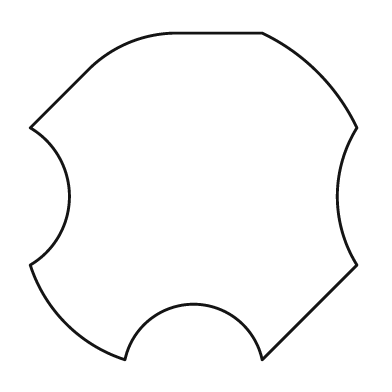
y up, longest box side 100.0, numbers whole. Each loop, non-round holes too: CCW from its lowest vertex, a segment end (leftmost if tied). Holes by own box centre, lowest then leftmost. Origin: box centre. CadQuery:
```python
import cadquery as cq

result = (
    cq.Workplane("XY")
    .moveTo(-21.0, -50.0)
    .threePointArc((0.0, -33.0), (21.0, -50.0))
    .lineTo(50.0, -21.0)
    .threePointArc((44.0, 0.0), (50.0, 21.0))
    .threePointArc((38.0, 38.0), (21.0, 50.0))
    .lineTo(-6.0, 50.0)
    .threePointArc((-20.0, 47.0), (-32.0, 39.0))
    .lineTo(-50.0, 21.0)
    .threePointArc((-38.0, 0.0), (-50.0, -21.0))
    .threePointArc((-39.0, -39.0), (-21.0, -50.0))
    .close()
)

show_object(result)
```